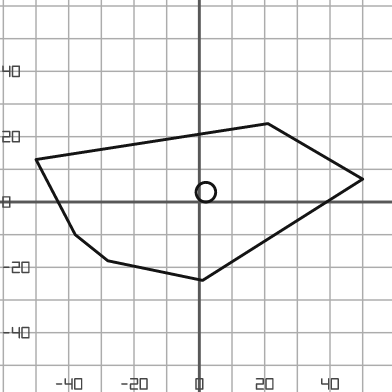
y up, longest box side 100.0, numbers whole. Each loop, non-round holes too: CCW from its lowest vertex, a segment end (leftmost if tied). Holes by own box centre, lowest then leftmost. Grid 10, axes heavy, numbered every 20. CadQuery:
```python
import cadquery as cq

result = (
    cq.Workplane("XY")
    .moveTo(1.0, -24.0)
    .lineTo(50.0, 7.0)
    .lineTo(21.0, 24.0)
    .lineTo(-50.0, 13.0)
    .lineTo(-38.0, -10.0)
    .lineTo(-28.0, -18.0)
    .close()
    .moveTo(2.0, 3.0)
    .circle(3.0)
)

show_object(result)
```